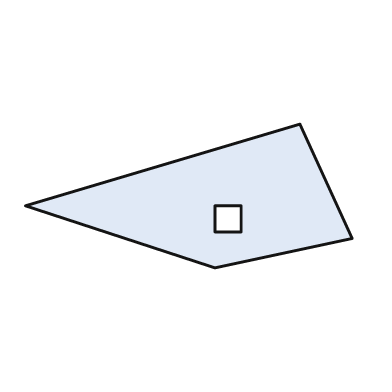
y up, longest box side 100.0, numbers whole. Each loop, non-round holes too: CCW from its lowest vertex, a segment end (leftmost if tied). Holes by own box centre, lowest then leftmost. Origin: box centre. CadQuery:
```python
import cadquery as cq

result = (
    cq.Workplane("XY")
    .moveTo(8.0, -22.0)
    .lineTo(50.0, -13.0)
    .lineTo(34.0, 22.0)
    .lineTo(-50.0, -3.0)
    .close()
    .moveTo(8.0, -11.0)
    .lineTo(16.0, -11.0)
    .lineTo(16.0, -3.0)
    .lineTo(8.0, -3.0)
    .close()
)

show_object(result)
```